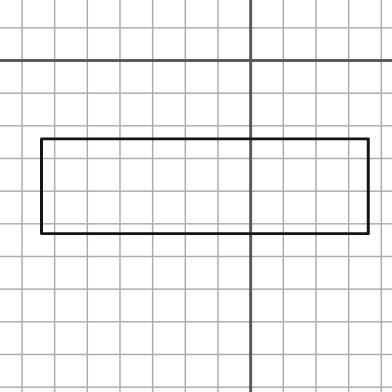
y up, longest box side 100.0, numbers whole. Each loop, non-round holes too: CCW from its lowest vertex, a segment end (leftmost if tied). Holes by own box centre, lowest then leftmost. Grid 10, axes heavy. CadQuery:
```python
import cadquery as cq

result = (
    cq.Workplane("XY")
    .moveTo(-64.0, -53.0)
    .lineTo(36.0, -53.0)
    .lineTo(36.0, -24.0)
    .lineTo(-64.0, -24.0)
    .close()
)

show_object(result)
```